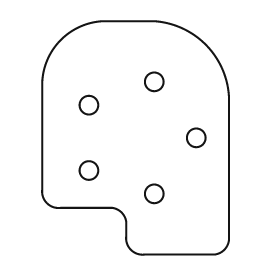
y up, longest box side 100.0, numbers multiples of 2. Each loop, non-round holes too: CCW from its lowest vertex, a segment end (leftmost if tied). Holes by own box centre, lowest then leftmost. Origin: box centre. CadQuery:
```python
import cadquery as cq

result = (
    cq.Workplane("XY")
    .moveTo(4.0, -50.0)
    .lineTo(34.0, -50.0)
    .threePointArc((38.0, -48.0), (40.0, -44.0))
    .lineTo(40.0, 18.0)
    .threePointArc((30.0, 40.0), (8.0, 50.0))
    .lineTo(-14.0, 50.0)
    .threePointArc((-32.0, 42.0), (-40.0, 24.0))
    .lineTo(-40.0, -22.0)
    .threePointArc((-38.0, -28.0), (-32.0, -30.0))
    .lineTo(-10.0, -30.0)
    .threePointArc((-6.0, -32.0), (-4.0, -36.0))
    .lineTo(-4.0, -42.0)
    .threePointArc((-2.0, -48.0), (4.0, -50.0))
    .close()
    .moveTo(8.0, -24.0)
    .circle(4.0)
    .moveTo(-20.0, -14.0)
    .circle(4.0)
    .moveTo(26.0, 0.0)
    .circle(4.0)
    .moveTo(-20.0, 14.0)
    .circle(4.0)
    .moveTo(8.0, 24.0)
    .circle(4.0)
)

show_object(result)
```